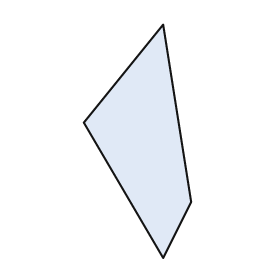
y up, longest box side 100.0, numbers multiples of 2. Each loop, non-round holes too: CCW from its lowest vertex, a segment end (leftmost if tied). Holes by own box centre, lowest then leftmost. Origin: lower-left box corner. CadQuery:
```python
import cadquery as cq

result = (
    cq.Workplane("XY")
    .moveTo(34.0, 0.0)
    .lineTo(46.0, 24.0)
    .lineTo(34.0, 100.0)
    .lineTo(0.0, 58.0)
    .close()
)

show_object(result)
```